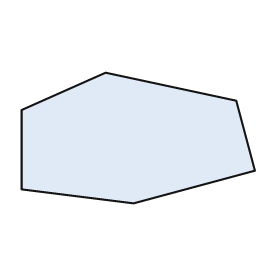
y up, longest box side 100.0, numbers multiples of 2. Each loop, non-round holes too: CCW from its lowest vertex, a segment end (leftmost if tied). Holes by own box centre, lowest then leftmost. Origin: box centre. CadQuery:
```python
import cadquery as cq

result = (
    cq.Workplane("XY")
    .moveTo(-2.0, -28.0)
    .lineTo(50.0, -14.0)
    .lineTo(42.0, 16.0)
    .lineTo(-14.0, 28.0)
    .lineTo(-50.0, 12.0)
    .lineTo(-50.0, -22.0)
    .close()
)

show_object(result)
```